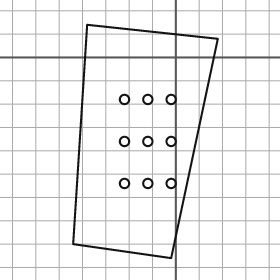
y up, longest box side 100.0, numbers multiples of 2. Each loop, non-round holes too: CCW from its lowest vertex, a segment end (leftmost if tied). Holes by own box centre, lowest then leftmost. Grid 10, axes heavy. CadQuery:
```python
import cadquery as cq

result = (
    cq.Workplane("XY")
    .moveTo(-2.0, -86.0)
    .lineTo(18.0, 8.0)
    .lineTo(-38.0, 14.0)
    .lineTo(-44.0, -80.0)
    .close()
    .moveTo(-22.0, -54.0)
    .circle(2.0)
    .moveTo(-12.0, -54.0)
    .circle(2.0)
    .moveTo(-2.0, -54.0)
    .circle(2.0)
    .moveTo(-22.0, -36.0)
    .circle(2.0)
    .moveTo(-12.0, -36.0)
    .circle(2.0)
    .moveTo(-2.0, -36.0)
    .circle(2.0)
    .moveTo(-22.0, -18.0)
    .circle(2.0)
    .moveTo(-12.0, -18.0)
    .circle(2.0)
    .moveTo(-2.0, -18.0)
    .circle(2.0)
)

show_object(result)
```